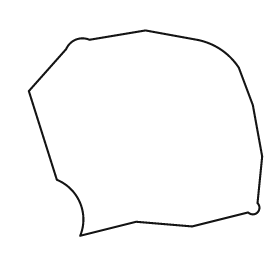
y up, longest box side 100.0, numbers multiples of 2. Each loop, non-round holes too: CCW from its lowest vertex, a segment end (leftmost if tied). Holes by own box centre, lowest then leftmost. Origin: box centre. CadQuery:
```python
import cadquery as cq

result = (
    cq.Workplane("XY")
    .moveTo(-28.0, -44.0)
    .lineTo(-4.0, -38.0)
    .lineTo(20.0, -40.0)
    .lineTo(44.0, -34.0)
    .threePointArc((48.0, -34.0), (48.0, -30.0))
    .lineTo(50.0, -10.0)
    .lineTo(46.0, 12.0)
    .lineTo(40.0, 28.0)
    .threePointArc((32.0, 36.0), (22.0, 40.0))
    .lineTo(0.0, 44.0)
    .lineTo(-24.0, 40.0)
    .threePointArc((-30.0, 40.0), (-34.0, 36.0))
    .lineTo(-50.0, 18.0)
    .lineTo(-38.0, -20.0)
    .threePointArc((-28.0, -30.0), (-28.0, -44.0))
    .close()
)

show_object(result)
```